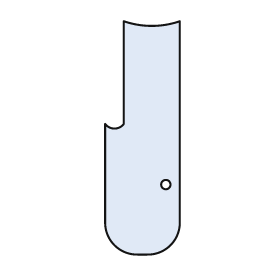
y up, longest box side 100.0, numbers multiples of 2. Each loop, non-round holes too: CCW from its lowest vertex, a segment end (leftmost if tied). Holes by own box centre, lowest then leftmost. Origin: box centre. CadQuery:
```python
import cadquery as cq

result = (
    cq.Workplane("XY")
    .moveTo(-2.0, -50.0)
    .lineTo(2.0, -50.0)
    .threePointArc((12.0, -46.0), (16.0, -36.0))
    .lineTo(16.0, 50.0)
    .threePointArc((4.0, 48.0), (-8.0, 50.0))
    .lineTo(-8.0, 6.0)
    .threePointArc((-12.0, 4.0), (-16.0, 6.0))
    .lineTo(-16.0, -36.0)
    .threePointArc((-12.0, -46.0), (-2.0, -50.0))
    .close()
    .moveTo(10.0, -20.0)
    .circle(2.0)
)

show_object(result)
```